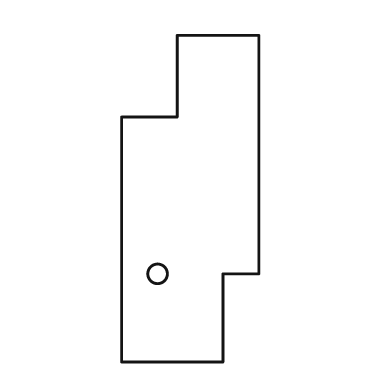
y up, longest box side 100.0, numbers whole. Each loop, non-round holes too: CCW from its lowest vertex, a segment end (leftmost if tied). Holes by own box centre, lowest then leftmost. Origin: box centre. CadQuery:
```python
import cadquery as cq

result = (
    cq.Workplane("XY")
    .moveTo(-21.0, -50.0)
    .lineTo(10.0, -50.0)
    .lineTo(10.0, -23.0)
    .lineTo(21.0, -23.0)
    .lineTo(21.0, 50.0)
    .lineTo(-4.0, 50.0)
    .lineTo(-4.0, 25.0)
    .lineTo(-21.0, 25.0)
    .close()
    .moveTo(-10.0, -23.0)
    .circle(3.0)
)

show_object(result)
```